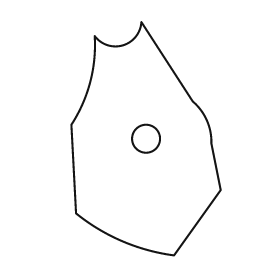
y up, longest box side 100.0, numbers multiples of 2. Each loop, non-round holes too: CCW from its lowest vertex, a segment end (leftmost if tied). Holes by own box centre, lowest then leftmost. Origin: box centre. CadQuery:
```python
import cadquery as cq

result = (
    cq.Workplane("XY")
    .moveTo(12.0, -50.0)
    .lineTo(32.0, -22.0)
    .lineTo(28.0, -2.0)
    .threePointArc((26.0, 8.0), (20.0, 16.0))
    .lineTo(-2.0, 50.0)
    .threePointArc((-10.0, 40.0), (-22.0, 44.0))
    .threePointArc((-24.0, 24.0), (-32.0, 6.0))
    .lineTo(-30.0, -32.0)
    .threePointArc((-10.0, -44.0), (12.0, -50.0))
    .close()
    .moveTo(0.0, 0.0)
    .circle(6.0)
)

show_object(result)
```